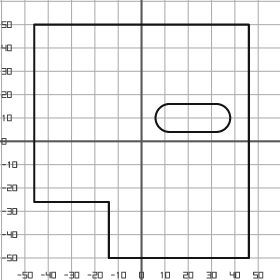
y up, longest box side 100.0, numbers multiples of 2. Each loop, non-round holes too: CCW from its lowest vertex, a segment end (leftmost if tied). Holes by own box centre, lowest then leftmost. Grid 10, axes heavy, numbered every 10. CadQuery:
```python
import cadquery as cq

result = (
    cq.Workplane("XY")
    .moveTo(-14.0, -50.0)
    .lineTo(46.0, -50.0)
    .lineTo(46.0, 50.0)
    .lineTo(-46.0, 50.0)
    .lineTo(-46.0, -26.0)
    .lineTo(-14.0, -26.0)
    .close()
    .moveTo(12.0, 4.0)
    .lineTo(32.0, 4.0)
    .threePointArc((38.0, 10.0), (32.0, 16.0))
    .lineTo(12.0, 16.0)
    .threePointArc((6.0, 10.0), (12.0, 4.0))
    .close()
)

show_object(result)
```